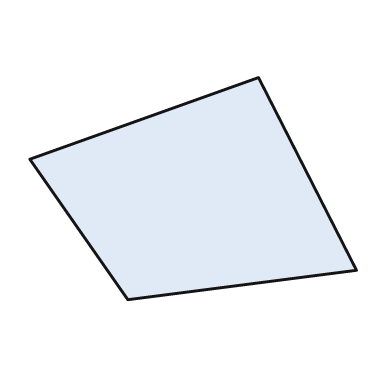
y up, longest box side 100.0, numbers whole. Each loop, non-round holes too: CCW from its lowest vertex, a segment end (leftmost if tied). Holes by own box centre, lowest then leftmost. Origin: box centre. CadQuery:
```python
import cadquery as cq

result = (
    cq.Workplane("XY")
    .moveTo(-20.0, -34.0)
    .lineTo(50.0, -25.0)
    .lineTo(20.0, 34.0)
    .lineTo(-50.0, 9.0)
    .close()
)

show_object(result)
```